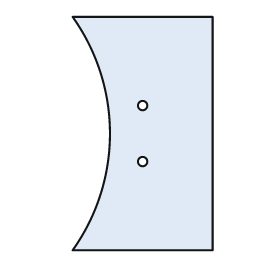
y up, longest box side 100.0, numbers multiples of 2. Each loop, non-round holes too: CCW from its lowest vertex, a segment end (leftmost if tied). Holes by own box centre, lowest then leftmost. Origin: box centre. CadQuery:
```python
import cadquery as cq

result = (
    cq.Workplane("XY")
    .moveTo(-30.0, -50.0)
    .lineTo(30.0, -50.0)
    .lineTo(30.0, 50.0)
    .lineTo(-30.0, 50.0)
    .threePointArc((-14.0, 0.0), (-30.0, -50.0))
    .close()
    .moveTo(0.0, -12.0)
    .circle(2.0)
    .moveTo(0.0, 12.0)
    .circle(2.0)
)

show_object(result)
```